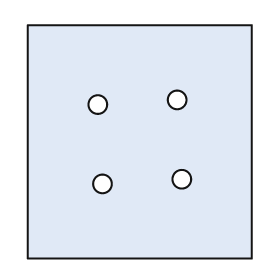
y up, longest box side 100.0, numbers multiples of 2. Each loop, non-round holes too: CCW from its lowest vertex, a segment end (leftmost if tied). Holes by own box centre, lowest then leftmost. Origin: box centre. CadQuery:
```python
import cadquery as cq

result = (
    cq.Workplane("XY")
    .moveTo(-48.0, -50.0)
    .lineTo(48.0, -50.0)
    .lineTo(48.0, 50.0)
    .lineTo(-48.0, 50.0)
    .close()
    .moveTo(-16.0, -18.0)
    .circle(4.0)
    .moveTo(18.0, -16.0)
    .circle(4.0)
    .moveTo(-18.0, 16.0)
    .circle(4.0)
    .moveTo(16.0, 18.0)
    .circle(4.0)
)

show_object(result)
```